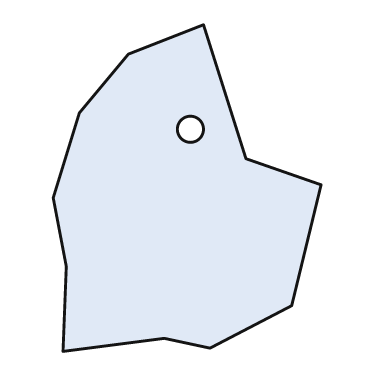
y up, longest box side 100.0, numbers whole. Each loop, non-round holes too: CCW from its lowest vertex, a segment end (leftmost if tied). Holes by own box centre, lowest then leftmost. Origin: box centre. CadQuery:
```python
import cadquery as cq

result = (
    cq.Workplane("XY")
    .moveTo(-38.0, -50.0)
    .lineTo(-7.0, -46.0)
    .lineTo(7.0, -49.0)
    .lineTo(32.0, -36.0)
    .lineTo(41.0, 1.0)
    .lineTo(18.0, 9.0)
    .lineTo(5.0, 50.0)
    .lineTo(-18.0, 41.0)
    .lineTo(-33.0, 23.0)
    .lineTo(-41.0, -3.0)
    .lineTo(-37.0, -24.0)
    .close()
    .moveTo(1.0, 18.0)
    .circle(4.0)
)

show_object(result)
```